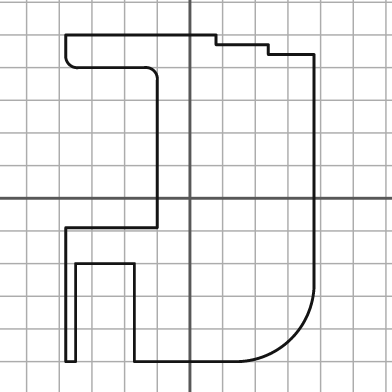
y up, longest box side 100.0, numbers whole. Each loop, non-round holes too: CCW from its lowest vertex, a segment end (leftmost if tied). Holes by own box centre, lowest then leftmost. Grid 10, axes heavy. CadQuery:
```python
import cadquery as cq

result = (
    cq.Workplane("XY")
    .moveTo(-38.0, -50.0)
    .lineTo(-35.0, -50.0)
    .lineTo(-35.0, -20.0)
    .lineTo(-17.0, -20.0)
    .lineTo(-17.0, -50.0)
    .lineTo(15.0, -50.0)
    .threePointArc((31.0, -43.0), (38.0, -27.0))
    .lineTo(38.0, 44.0)
    .lineTo(24.0, 44.0)
    .lineTo(24.0, 47.0)
    .lineTo(8.0, 47.0)
    .lineTo(8.0, 50.0)
    .lineTo(-38.0, 50.0)
    .lineTo(-38.0, 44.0)
    .threePointArc((-37.0, 41.0), (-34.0, 40.0))
    .lineTo(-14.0, 40.0)
    .threePointArc((-11.0, 39.0), (-10.0, 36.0))
    .lineTo(-10.0, -9.0)
    .lineTo(-38.0, -9.0)
    .close()
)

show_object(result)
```